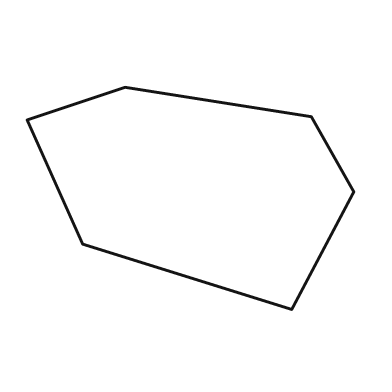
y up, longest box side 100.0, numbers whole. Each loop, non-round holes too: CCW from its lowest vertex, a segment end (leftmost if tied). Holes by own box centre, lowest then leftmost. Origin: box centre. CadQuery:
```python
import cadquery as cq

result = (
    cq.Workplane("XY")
    .moveTo(31.0, -34.0)
    .lineTo(50.0, 2.0)
    .lineTo(37.0, 25.0)
    .lineTo(-20.0, 34.0)
    .lineTo(-50.0, 24.0)
    .lineTo(-33.0, -14.0)
    .close()
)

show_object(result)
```